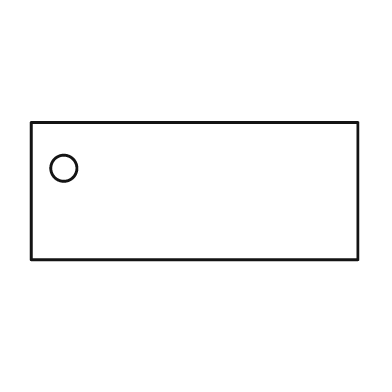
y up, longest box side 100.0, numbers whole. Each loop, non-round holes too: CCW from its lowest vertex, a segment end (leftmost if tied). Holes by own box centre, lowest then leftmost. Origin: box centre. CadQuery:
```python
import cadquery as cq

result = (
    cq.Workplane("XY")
    .moveTo(-50.0, -21.0)
    .lineTo(50.0, -21.0)
    .lineTo(50.0, 21.0)
    .lineTo(-50.0, 21.0)
    .close()
    .moveTo(-40.0, 7.0)
    .circle(4.0)
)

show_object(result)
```